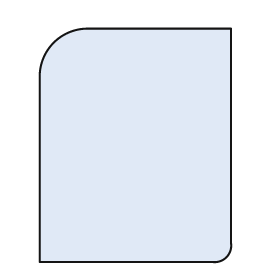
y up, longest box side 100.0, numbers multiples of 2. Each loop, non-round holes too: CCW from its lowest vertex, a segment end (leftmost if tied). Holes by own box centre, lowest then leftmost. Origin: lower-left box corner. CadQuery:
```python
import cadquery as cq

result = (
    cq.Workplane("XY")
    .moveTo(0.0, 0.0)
    .lineTo(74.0, 0.0)
    .threePointArc((80.0, 2.0), (82.0, 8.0))
    .lineTo(82.0, 100.0)
    .lineTo(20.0, 100.0)
    .threePointArc((6.0, 94.0), (0.0, 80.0))
    .close()
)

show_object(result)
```